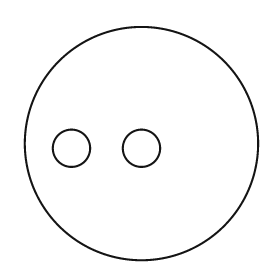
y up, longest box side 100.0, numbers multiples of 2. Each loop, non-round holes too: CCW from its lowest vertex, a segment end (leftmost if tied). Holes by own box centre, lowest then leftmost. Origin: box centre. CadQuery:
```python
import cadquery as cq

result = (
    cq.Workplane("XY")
    .moveTo(0.0, 0.0)
    .circle(50.0)
    .moveTo(-30.0, -2.0)
    .circle(8.0)
    .moveTo(0.0, -2.0)
    .circle(8.0)
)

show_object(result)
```